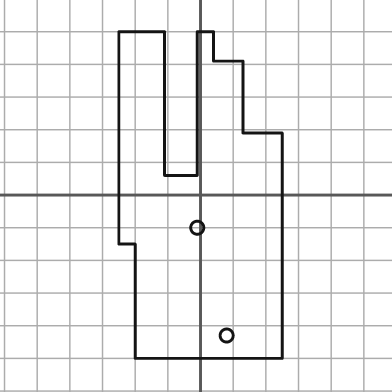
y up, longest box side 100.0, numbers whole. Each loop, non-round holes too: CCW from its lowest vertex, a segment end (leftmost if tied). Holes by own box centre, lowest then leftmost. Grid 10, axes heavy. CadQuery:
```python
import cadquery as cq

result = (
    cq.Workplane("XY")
    .moveTo(-20.0, -50.0)
    .lineTo(25.0, -50.0)
    .lineTo(25.0, 19.0)
    .lineTo(13.0, 19.0)
    .lineTo(13.0, 41.0)
    .lineTo(4.0, 41.0)
    .lineTo(4.0, 50.0)
    .lineTo(-1.0, 50.0)
    .lineTo(-1.0, 6.0)
    .lineTo(-11.0, 6.0)
    .lineTo(-11.0, 50.0)
    .lineTo(-25.0, 50.0)
    .lineTo(-25.0, -15.0)
    .lineTo(-20.0, -15.0)
    .close()
    .moveTo(8.0, -43.0)
    .circle(2.0)
    .moveTo(-1.0, -10.0)
    .circle(2.0)
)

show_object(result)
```